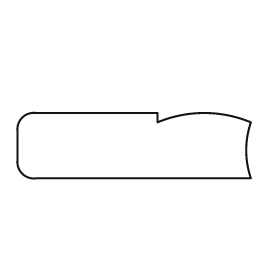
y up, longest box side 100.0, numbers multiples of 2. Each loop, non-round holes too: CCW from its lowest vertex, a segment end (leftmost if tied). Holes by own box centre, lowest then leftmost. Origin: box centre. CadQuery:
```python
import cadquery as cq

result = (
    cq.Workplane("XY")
    .moveTo(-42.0, -14.0)
    .lineTo(50.0, -14.0)
    .threePointArc((48.0, -2.0), (50.0, 10.0))
    .threePointArc((30.0, 14.0), (10.0, 10.0))
    .lineTo(10.0, 14.0)
    .lineTo(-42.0, 14.0)
    .threePointArc((-48.0, 12.0), (-50.0, 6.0))
    .lineTo(-50.0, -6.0)
    .threePointArc((-48.0, -12.0), (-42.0, -14.0))
    .close()
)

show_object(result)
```